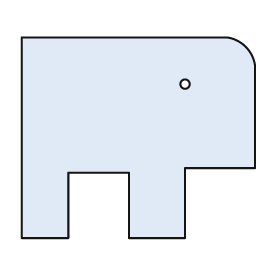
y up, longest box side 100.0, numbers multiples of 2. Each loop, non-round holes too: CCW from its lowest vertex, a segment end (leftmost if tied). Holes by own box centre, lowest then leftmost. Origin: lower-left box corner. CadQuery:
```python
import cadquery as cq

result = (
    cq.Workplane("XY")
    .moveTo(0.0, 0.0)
    .lineTo(20.0, 0.0)
    .lineTo(20.0, 28.0)
    .lineTo(46.0, 28.0)
    .lineTo(46.0, 0.0)
    .lineTo(70.0, 0.0)
    .lineTo(70.0, 30.0)
    .lineTo(100.0, 30.0)
    .lineTo(100.0, 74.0)
    .threePointArc((96.0, 82.0), (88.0, 86.0))
    .lineTo(0.0, 86.0)
    .close()
    .moveTo(70.0, 66.0)
    .circle(2.0)
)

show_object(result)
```